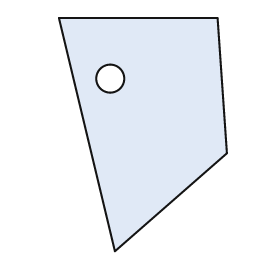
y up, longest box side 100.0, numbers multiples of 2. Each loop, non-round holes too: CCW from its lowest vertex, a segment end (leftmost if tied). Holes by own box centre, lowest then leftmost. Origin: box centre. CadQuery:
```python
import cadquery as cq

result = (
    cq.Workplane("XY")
    .moveTo(-12.0, -50.0)
    .lineTo(36.0, -8.0)
    .lineTo(32.0, 50.0)
    .lineTo(-36.0, 50.0)
    .close()
    .moveTo(-14.0, 24.0)
    .circle(6.0)
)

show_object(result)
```